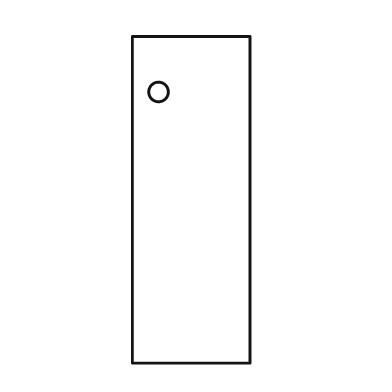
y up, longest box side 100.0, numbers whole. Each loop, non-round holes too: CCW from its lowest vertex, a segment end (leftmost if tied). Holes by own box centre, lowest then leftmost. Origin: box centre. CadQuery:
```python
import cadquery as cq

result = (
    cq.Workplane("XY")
    .moveTo(-18.0, -50.0)
    .lineTo(18.0, -50.0)
    .lineTo(18.0, 50.0)
    .lineTo(-18.0, 50.0)
    .close()
    .moveTo(-10.0, 33.0)
    .circle(3.0)
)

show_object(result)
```